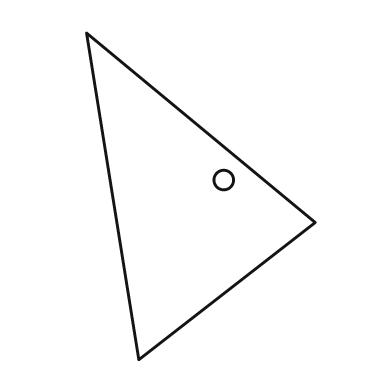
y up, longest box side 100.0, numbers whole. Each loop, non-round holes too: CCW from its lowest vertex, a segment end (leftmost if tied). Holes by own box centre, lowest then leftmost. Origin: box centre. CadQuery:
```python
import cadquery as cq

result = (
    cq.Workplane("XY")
    .moveTo(-19.0, -50.0)
    .lineTo(35.0, -8.0)
    .lineTo(-35.0, 50.0)
    .close()
    .moveTo(7.0, 5.0)
    .circle(3.0)
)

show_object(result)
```